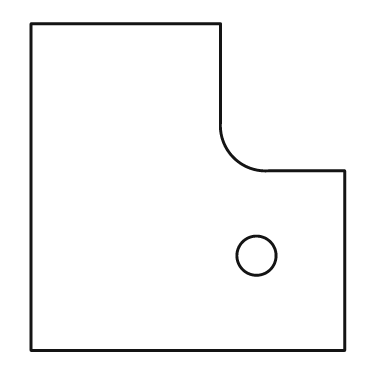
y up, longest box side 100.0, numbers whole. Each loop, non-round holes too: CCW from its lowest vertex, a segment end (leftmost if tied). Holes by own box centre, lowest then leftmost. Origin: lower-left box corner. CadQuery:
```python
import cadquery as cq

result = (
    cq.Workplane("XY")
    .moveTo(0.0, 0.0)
    .lineTo(96.0, 0.0)
    .lineTo(96.0, 55.0)
    .lineTo(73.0, 55.0)
    .threePointArc((62.0, 59.0), (58.0, 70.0))
    .lineTo(58.0, 100.0)
    .lineTo(0.0, 100.0)
    .close()
    .moveTo(69.0, 29.0)
    .circle(6.0)
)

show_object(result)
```